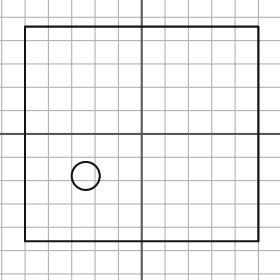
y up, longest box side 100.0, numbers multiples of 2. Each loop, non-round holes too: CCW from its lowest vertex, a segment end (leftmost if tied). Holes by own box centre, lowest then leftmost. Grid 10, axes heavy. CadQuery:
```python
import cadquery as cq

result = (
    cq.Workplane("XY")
    .moveTo(-50.0, -46.0)
    .lineTo(50.0, -46.0)
    .lineTo(50.0, 46.0)
    .lineTo(-50.0, 46.0)
    .close()
    .moveTo(-24.0, -18.0)
    .circle(6.0)
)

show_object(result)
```